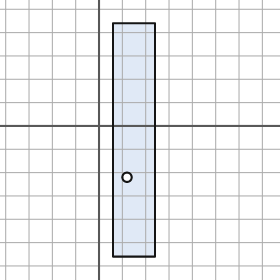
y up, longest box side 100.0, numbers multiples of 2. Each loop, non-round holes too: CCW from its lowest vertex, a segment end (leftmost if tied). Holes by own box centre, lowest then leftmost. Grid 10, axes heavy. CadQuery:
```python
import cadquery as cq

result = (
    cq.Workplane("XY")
    .moveTo(6.0, -56.0)
    .lineTo(24.0, -56.0)
    .lineTo(24.0, 44.0)
    .lineTo(6.0, 44.0)
    .close()
    .moveTo(12.0, -22.0)
    .circle(2.0)
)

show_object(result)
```